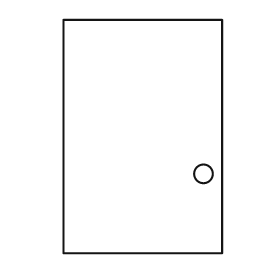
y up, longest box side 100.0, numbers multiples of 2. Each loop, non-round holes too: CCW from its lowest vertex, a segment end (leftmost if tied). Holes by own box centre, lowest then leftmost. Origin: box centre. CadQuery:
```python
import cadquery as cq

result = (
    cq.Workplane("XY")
    .moveTo(-34.0, -50.0)
    .lineTo(34.0, -50.0)
    .lineTo(34.0, 50.0)
    .lineTo(-34.0, 50.0)
    .close()
    .moveTo(26.0, -16.0)
    .circle(4.0)
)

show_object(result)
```